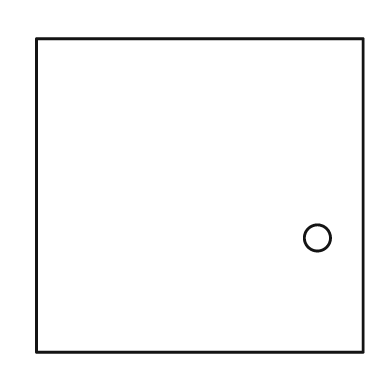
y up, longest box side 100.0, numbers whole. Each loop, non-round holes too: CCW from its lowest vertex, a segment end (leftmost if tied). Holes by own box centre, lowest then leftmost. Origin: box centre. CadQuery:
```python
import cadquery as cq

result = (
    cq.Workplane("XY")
    .moveTo(-50.0, -48.0)
    .lineTo(50.0, -48.0)
    .lineTo(50.0, 48.0)
    .lineTo(-50.0, 48.0)
    .close()
    .moveTo(36.0, -13.0)
    .circle(4.0)
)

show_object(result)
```